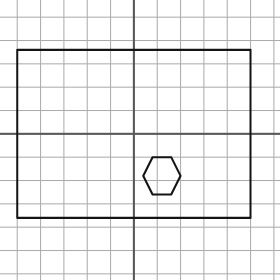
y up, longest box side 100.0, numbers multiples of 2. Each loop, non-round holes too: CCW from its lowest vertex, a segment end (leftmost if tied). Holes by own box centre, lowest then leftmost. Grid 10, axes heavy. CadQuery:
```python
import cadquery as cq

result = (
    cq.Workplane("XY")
    .moveTo(-50.0, -36.0)
    .lineTo(50.0, -36.0)
    .lineTo(50.0, 36.0)
    .lineTo(-50.0, 36.0)
    .close()
    .moveTo(8.0, -26.0)
    .lineTo(16.0, -26.0)
    .lineTo(20.0, -18.0)
    .lineTo(16.0, -10.0)
    .lineTo(8.0, -10.0)
    .lineTo(4.0, -18.0)
    .close()
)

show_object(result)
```